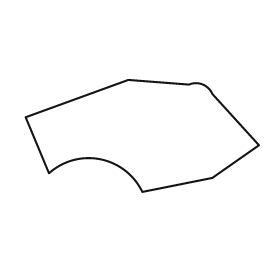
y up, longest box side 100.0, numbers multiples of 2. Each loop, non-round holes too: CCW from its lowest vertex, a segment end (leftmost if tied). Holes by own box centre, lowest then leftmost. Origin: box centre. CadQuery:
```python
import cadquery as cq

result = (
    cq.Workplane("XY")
    .moveTo(0.0, -24.0)
    .lineTo(30.0, -18.0)
    .lineTo(50.0, -4.0)
    .lineTo(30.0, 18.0)
    .threePointArc((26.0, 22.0), (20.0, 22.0))
    .lineTo(-6.0, 24.0)
    .lineTo(-50.0, 8.0)
    .lineTo(-40.0, -16.0)
    .threePointArc((-18.0, -10.0), (0.0, -24.0))
    .close()
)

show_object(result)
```